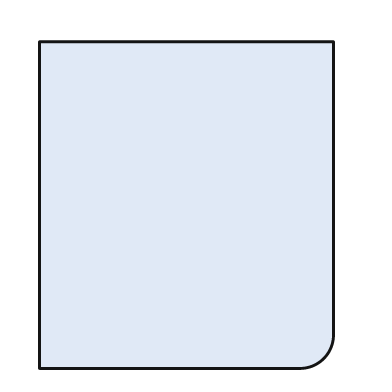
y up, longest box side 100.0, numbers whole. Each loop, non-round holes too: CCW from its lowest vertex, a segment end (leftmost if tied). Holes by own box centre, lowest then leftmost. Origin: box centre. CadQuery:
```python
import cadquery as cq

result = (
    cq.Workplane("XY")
    .moveTo(-45.0, -50.0)
    .lineTo(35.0, -50.0)
    .threePointArc((42.0, -47.0), (45.0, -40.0))
    .lineTo(45.0, 50.0)
    .lineTo(-45.0, 50.0)
    .close()
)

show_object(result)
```